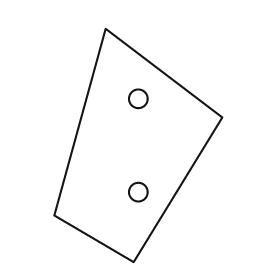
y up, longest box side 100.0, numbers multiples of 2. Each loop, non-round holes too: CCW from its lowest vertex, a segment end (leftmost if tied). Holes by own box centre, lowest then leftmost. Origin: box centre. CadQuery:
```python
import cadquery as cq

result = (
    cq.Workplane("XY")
    .moveTo(-2.0, -50.0)
    .lineTo(36.0, 12.0)
    .lineTo(-14.0, 50.0)
    .lineTo(-36.0, -30.0)
    .close()
    .moveTo(0.0, -20.0)
    .circle(4.0)
    .moveTo(0.0, 20.0)
    .circle(4.0)
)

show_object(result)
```